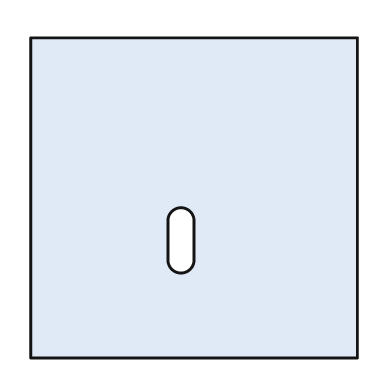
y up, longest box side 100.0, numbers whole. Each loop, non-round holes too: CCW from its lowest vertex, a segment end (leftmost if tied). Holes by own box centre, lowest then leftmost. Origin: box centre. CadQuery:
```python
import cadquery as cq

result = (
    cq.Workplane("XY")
    .moveTo(-50.0, -49.0)
    .lineTo(50.0, -49.0)
    .lineTo(50.0, 49.0)
    .lineTo(-50.0, 49.0)
    .close()
    .moveTo(-8.0, -19.0)
    .threePointArc((-4.0, -23.0), (0.0, -19.0))
    .lineTo(0.0, -7.0)
    .threePointArc((-4.0, -3.0), (-8.0, -7.0))
    .close()
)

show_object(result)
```